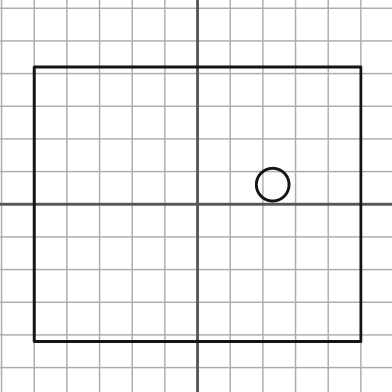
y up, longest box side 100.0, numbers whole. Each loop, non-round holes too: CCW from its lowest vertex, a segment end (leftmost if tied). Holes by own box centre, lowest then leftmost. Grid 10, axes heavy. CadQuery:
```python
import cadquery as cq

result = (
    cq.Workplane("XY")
    .moveTo(-50.0, -42.0)
    .lineTo(50.0, -42.0)
    .lineTo(50.0, 42.0)
    .lineTo(-50.0, 42.0)
    .close()
    .moveTo(23.0, 6.0)
    .circle(5.0)
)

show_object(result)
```